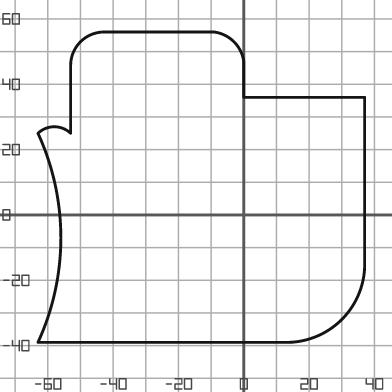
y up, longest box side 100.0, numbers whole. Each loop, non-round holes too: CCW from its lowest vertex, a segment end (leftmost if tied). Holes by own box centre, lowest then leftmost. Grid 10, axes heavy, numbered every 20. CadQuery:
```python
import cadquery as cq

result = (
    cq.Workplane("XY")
    .moveTo(-63.0, -39.0)
    .lineTo(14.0, -39.0)
    .threePointArc((30.0, -32.0), (37.0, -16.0))
    .lineTo(37.0, 36.0)
    .lineTo(0.0, 36.0)
    .lineTo(0.0, 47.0)
    .threePointArc((-3.0, 53.0), (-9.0, 56.0))
    .lineTo(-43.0, 56.0)
    .threePointArc((-50.0, 53.0), (-53.0, 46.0))
    .lineTo(-53.0, 25.0)
    .threePointArc((-58.0, 27.0), (-63.0, 25.0))
    .threePointArc((-56.0, -7.0), (-63.0, -39.0))
    .close()
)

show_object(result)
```